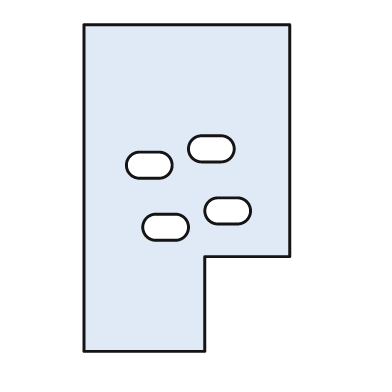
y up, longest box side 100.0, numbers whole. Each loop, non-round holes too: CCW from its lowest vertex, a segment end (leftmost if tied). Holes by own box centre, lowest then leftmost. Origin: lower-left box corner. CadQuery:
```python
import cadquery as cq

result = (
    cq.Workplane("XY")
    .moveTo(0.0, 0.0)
    .lineTo(37.0, 0.0)
    .lineTo(37.0, 29.0)
    .lineTo(63.0, 29.0)
    .lineTo(63.0, 100.0)
    .lineTo(0.0, 100.0)
    .close()
    .moveTo(22.0, 34.0)
    .lineTo(28.0, 34.0)
    .threePointArc((32.0, 38.0), (28.0, 42.0))
    .lineTo(22.0, 42.0)
    .threePointArc((18.0, 38.0), (22.0, 34.0))
    .close()
    .moveTo(41.0, 39.0)
    .lineTo(47.0, 39.0)
    .threePointArc((51.0, 43.0), (47.0, 47.0))
    .lineTo(41.0, 47.0)
    .threePointArc((37.0, 43.0), (41.0, 39.0))
    .close()
    .moveTo(17.0, 53.0)
    .lineTo(23.0, 53.0)
    .threePointArc((27.0, 57.0), (23.0, 61.0))
    .lineTo(17.0, 61.0)
    .threePointArc((13.0, 57.0), (17.0, 53.0))
    .close()
    .moveTo(36.0, 58.0)
    .lineTo(42.0, 58.0)
    .threePointArc((46.0, 62.0), (42.0, 66.0))
    .lineTo(36.0, 66.0)
    .threePointArc((32.0, 62.0), (36.0, 58.0))
    .close()
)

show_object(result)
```